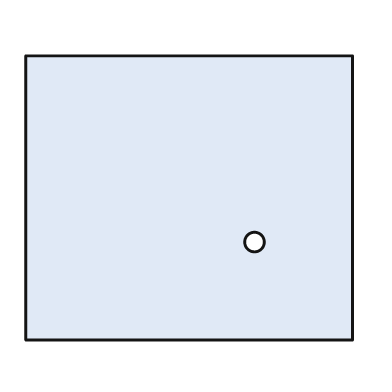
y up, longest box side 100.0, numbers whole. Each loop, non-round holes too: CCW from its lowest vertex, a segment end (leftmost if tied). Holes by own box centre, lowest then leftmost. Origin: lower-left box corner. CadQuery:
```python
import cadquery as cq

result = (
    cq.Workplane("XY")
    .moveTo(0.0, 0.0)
    .lineTo(100.0, 0.0)
    .lineTo(100.0, 87.0)
    .lineTo(0.0, 87.0)
    .close()
    .moveTo(70.0, 30.0)
    .circle(3.0)
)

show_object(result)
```